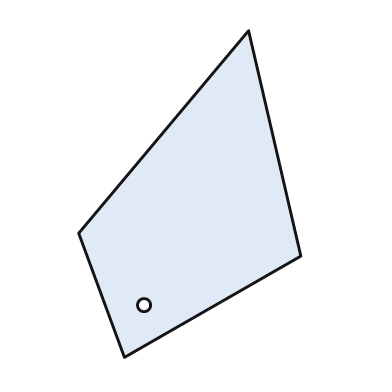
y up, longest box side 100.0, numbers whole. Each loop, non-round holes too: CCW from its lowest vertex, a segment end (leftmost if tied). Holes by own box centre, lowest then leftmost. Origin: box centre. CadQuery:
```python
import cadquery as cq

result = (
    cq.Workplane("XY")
    .moveTo(-20.0, -50.0)
    .lineTo(34.0, -19.0)
    .lineTo(18.0, 50.0)
    .lineTo(-34.0, -12.0)
    .close()
    .moveTo(-14.0, -34.0)
    .circle(2.0)
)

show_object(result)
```